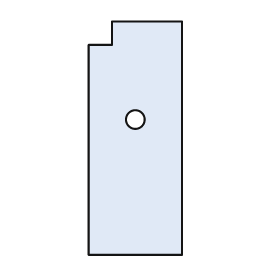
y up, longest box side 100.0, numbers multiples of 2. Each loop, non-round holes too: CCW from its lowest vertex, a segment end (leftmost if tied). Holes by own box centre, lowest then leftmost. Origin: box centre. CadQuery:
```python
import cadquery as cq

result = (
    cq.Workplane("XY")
    .moveTo(-20.0, -50.0)
    .lineTo(20.0, -50.0)
    .lineTo(20.0, 50.0)
    .lineTo(-10.0, 50.0)
    .lineTo(-10.0, 40.0)
    .lineTo(-20.0, 40.0)
    .close()
    .moveTo(0.0, 8.0)
    .circle(4.0)
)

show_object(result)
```